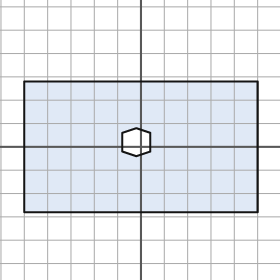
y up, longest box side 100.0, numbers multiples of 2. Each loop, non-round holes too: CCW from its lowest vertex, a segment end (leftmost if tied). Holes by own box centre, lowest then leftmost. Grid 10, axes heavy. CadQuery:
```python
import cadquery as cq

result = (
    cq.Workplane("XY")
    .moveTo(-50.0, -28.0)
    .lineTo(50.0, -28.0)
    .lineTo(50.0, 28.0)
    .lineTo(-50.0, 28.0)
    .close()
    .moveTo(-2.0, -4.0)
    .lineTo(4.0, -2.0)
    .lineTo(4.0, 6.0)
    .lineTo(-2.0, 8.0)
    .lineTo(-8.0, 6.0)
    .lineTo(-8.0, -2.0)
    .close()
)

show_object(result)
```